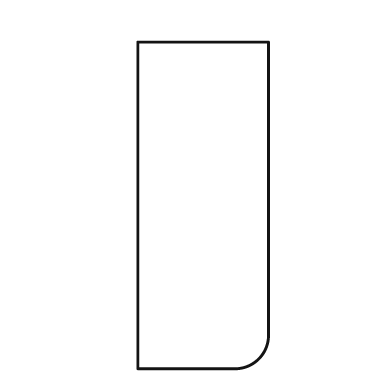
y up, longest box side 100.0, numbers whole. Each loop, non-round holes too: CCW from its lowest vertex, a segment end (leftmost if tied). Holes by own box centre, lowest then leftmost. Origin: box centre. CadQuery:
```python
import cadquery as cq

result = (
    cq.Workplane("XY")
    .moveTo(-20.0, -50.0)
    .lineTo(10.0, -50.0)
    .threePointArc((17.0, -47.0), (20.0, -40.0))
    .lineTo(20.0, 50.0)
    .lineTo(-20.0, 50.0)
    .close()
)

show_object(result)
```